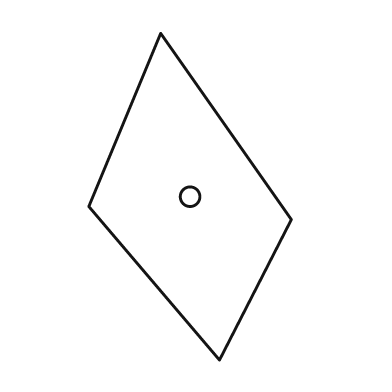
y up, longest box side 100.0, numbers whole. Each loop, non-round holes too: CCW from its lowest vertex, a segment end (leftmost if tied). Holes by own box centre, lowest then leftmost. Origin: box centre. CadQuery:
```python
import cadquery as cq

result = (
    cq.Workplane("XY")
    .moveTo(9.0, -50.0)
    .lineTo(31.0, -7.0)
    .lineTo(-9.0, 50.0)
    .lineTo(-31.0, -3.0)
    .close()
    .moveTo(0.0, 0.0)
    .circle(3.0)
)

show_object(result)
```